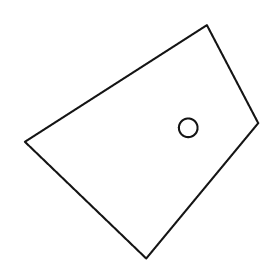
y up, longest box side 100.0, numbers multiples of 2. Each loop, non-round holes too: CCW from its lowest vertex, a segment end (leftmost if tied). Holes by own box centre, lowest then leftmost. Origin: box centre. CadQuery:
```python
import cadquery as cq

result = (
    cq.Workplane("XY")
    .moveTo(2.0, -50.0)
    .lineTo(50.0, 8.0)
    .lineTo(28.0, 50.0)
    .lineTo(-50.0, 0.0)
    .close()
    .moveTo(20.0, 6.0)
    .circle(4.0)
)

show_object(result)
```